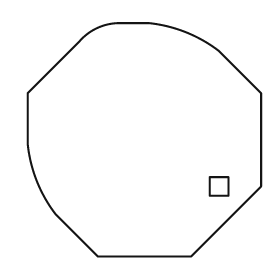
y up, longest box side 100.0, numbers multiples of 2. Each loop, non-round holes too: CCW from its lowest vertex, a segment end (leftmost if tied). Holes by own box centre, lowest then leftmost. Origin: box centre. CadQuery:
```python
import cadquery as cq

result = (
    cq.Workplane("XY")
    .moveTo(-20.0, -50.0)
    .lineTo(20.0, -50.0)
    .lineTo(50.0, -20.0)
    .lineTo(50.0, 20.0)
    .lineTo(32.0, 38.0)
    .threePointArc((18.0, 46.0), (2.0, 50.0))
    .lineTo(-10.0, 50.0)
    .threePointArc((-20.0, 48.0), (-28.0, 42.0))
    .lineTo(-50.0, 20.0)
    .lineTo(-50.0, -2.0)
    .threePointArc((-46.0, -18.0), (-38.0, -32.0))
    .close()
    .moveTo(28.0, -24.0)
    .lineTo(36.0, -24.0)
    .lineTo(36.0, -16.0)
    .lineTo(28.0, -16.0)
    .close()
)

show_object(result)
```